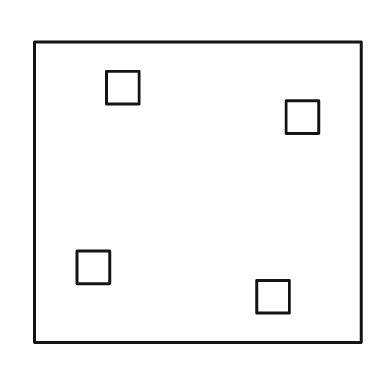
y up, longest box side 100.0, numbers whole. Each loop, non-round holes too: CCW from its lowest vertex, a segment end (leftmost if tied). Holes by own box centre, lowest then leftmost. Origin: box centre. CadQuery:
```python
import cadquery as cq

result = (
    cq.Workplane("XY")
    .moveTo(-50.0, -46.0)
    .lineTo(50.0, -46.0)
    .lineTo(50.0, 46.0)
    .lineTo(-50.0, 46.0)
    .close()
    .moveTo(18.0, -37.0)
    .lineTo(28.0, -37.0)
    .lineTo(28.0, -27.0)
    .lineTo(18.0, -27.0)
    .close()
    .moveTo(-37.0, -28.0)
    .lineTo(-27.0, -28.0)
    .lineTo(-27.0, -18.0)
    .lineTo(-37.0, -18.0)
    .close()
    .moveTo(27.0, 18.0)
    .lineTo(37.0, 18.0)
    .lineTo(37.0, 28.0)
    .lineTo(27.0, 28.0)
    .close()
    .moveTo(-28.0, 27.0)
    .lineTo(-18.0, 27.0)
    .lineTo(-18.0, 37.0)
    .lineTo(-28.0, 37.0)
    .close()
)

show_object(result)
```